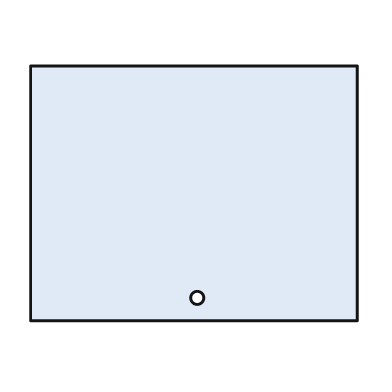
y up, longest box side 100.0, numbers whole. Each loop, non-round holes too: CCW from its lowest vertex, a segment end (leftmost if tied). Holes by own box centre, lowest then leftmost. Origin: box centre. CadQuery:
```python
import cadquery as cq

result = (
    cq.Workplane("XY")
    .moveTo(-50.0, -39.0)
    .lineTo(50.0, -39.0)
    .lineTo(50.0, 39.0)
    .lineTo(-50.0, 39.0)
    .close()
    .moveTo(1.0, -32.0)
    .circle(2.0)
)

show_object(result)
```